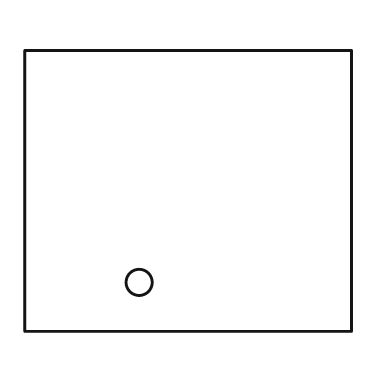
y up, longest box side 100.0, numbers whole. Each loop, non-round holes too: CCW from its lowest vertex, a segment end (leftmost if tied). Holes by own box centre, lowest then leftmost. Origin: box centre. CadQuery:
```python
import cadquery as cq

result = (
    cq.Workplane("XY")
    .moveTo(-50.0, -43.0)
    .lineTo(50.0, -43.0)
    .lineTo(50.0, 43.0)
    .lineTo(-50.0, 43.0)
    .close()
    .moveTo(-15.0, -28.0)
    .circle(4.0)
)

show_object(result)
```